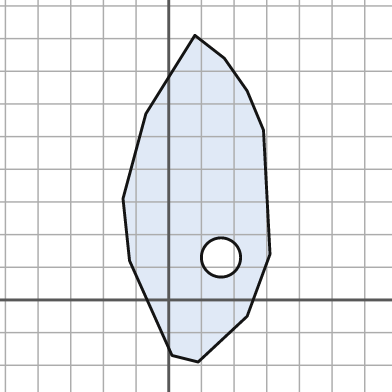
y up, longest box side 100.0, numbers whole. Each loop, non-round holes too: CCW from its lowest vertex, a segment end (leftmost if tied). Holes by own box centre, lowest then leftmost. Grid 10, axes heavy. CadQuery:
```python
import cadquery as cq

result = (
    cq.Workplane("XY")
    .moveTo(9.0, -19.0)
    .lineTo(24.0, -5.0)
    .lineTo(31.0, 14.0)
    .lineTo(29.0, 52.0)
    .lineTo(24.0, 64.0)
    .lineTo(17.0, 74.0)
    .lineTo(8.0, 81.0)
    .lineTo(-7.0, 57.0)
    .lineTo(-14.0, 31.0)
    .lineTo(-12.0, 12.0)
    .lineTo(1.0, -17.0)
    .close()
    .moveTo(16.0, 13.0)
    .circle(6.0)
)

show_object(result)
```